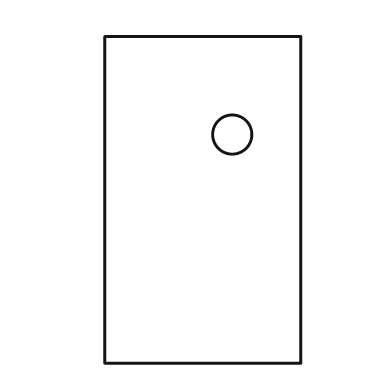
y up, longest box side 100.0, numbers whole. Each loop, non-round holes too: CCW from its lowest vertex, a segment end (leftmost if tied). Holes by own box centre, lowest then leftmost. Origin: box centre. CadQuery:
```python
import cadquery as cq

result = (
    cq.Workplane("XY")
    .moveTo(-30.0, -50.0)
    .lineTo(30.0, -50.0)
    .lineTo(30.0, 50.0)
    .lineTo(-30.0, 50.0)
    .close()
    .moveTo(9.0, 20.0)
    .circle(6.0)
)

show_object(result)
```